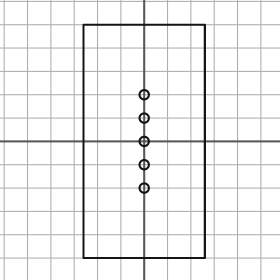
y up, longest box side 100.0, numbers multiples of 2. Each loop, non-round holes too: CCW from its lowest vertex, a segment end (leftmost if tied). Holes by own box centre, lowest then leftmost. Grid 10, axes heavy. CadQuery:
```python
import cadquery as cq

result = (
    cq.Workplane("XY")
    .moveTo(-26.0, -50.0)
    .lineTo(26.0, -50.0)
    .lineTo(26.0, 50.0)
    .lineTo(-26.0, 50.0)
    .close()
    .moveTo(0.0, -20.0)
    .circle(2.0)
    .moveTo(0.0, -10.0)
    .circle(2.0)
    .moveTo(0.0, 0.0)
    .circle(2.0)
    .moveTo(0.0, 10.0)
    .circle(2.0)
    .moveTo(0.0, 20.0)
    .circle(2.0)
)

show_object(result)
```